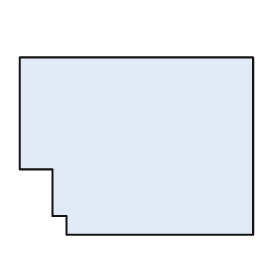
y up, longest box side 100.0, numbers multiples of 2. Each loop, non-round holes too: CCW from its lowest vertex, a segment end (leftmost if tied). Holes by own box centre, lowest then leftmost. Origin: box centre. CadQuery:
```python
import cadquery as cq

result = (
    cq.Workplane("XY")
    .moveTo(-30.0, -38.0)
    .lineTo(50.0, -38.0)
    .lineTo(50.0, 38.0)
    .lineTo(-50.0, 38.0)
    .lineTo(-50.0, -10.0)
    .lineTo(-36.0, -10.0)
    .lineTo(-36.0, -30.0)
    .lineTo(-30.0, -30.0)
    .close()
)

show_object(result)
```